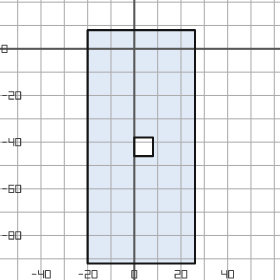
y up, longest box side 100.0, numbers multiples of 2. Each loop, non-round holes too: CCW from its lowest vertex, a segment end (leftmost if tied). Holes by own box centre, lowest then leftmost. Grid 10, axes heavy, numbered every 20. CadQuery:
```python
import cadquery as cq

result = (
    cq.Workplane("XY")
    .moveTo(-20.0, -92.0)
    .lineTo(26.0, -92.0)
    .lineTo(26.0, 8.0)
    .lineTo(-20.0, 8.0)
    .close()
    .moveTo(0.0, -46.0)
    .lineTo(8.0, -46.0)
    .lineTo(8.0, -38.0)
    .lineTo(0.0, -38.0)
    .close()
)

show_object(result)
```